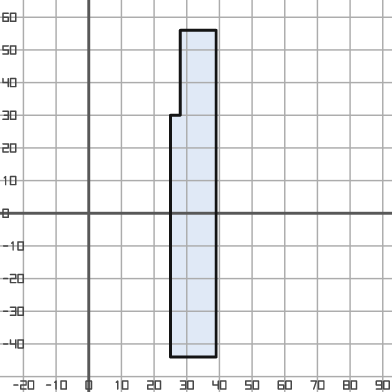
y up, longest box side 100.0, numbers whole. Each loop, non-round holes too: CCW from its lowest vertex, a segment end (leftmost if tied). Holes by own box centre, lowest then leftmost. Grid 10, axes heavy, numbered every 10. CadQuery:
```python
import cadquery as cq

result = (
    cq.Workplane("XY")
    .moveTo(25.0, -44.0)
    .lineTo(39.0, -44.0)
    .lineTo(39.0, 56.0)
    .lineTo(28.0, 56.0)
    .lineTo(28.0, 30.0)
    .lineTo(25.0, 30.0)
    .close()
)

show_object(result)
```